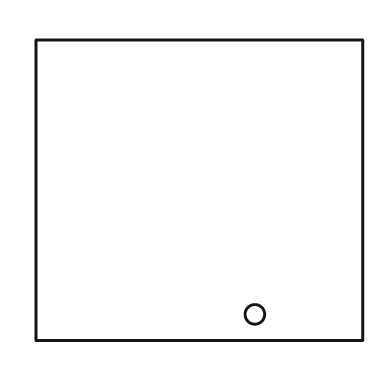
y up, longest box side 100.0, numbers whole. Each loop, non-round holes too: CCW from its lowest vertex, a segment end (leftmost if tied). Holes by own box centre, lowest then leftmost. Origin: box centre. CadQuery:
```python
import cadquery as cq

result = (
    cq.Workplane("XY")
    .moveTo(-50.0, -46.0)
    .lineTo(50.0, -46.0)
    .lineTo(50.0, 46.0)
    .lineTo(-50.0, 46.0)
    .close()
    .moveTo(17.0, -38.0)
    .circle(3.0)
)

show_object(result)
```